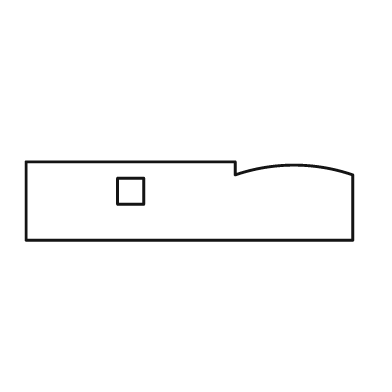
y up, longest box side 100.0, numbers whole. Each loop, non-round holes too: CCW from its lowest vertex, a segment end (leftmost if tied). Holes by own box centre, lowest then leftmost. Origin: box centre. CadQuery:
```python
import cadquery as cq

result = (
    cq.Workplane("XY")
    .moveTo(-50.0, -12.0)
    .lineTo(50.0, -12.0)
    .lineTo(50.0, 8.0)
    .threePointArc((32.0, 11.0), (14.0, 8.0))
    .lineTo(14.0, 12.0)
    .lineTo(-50.0, 12.0)
    .close()
    .moveTo(-22.0, -1.0)
    .lineTo(-14.0, -1.0)
    .lineTo(-14.0, 7.0)
    .lineTo(-22.0, 7.0)
    .close()
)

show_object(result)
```